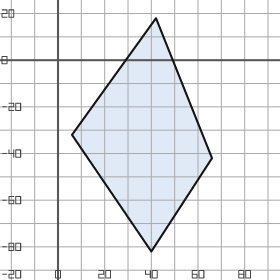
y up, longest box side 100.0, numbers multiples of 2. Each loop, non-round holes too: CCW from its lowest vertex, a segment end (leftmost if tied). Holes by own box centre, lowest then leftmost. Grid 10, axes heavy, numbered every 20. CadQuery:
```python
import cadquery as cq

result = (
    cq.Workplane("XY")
    .moveTo(40.0, -82.0)
    .lineTo(66.0, -42.0)
    .lineTo(42.0, 18.0)
    .lineTo(6.0, -32.0)
    .close()
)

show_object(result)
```